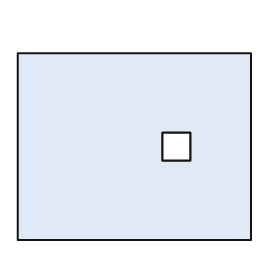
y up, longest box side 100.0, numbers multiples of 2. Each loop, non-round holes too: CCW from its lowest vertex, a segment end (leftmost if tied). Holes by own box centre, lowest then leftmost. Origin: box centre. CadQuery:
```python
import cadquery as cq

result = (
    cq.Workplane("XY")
    .moveTo(-50.0, -40.0)
    .lineTo(50.0, -40.0)
    .lineTo(50.0, 40.0)
    .lineTo(-50.0, 40.0)
    .close()
    .moveTo(12.0, -6.0)
    .lineTo(24.0, -6.0)
    .lineTo(24.0, 6.0)
    .lineTo(12.0, 6.0)
    .close()
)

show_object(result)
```